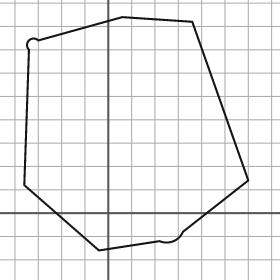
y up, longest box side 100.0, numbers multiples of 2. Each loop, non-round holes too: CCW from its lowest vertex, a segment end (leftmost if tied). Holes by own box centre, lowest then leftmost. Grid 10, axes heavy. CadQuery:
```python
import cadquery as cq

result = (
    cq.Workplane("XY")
    .moveTo(-4.0, -16.0)
    .lineTo(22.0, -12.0)
    .threePointArc((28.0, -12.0), (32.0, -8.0))
    .lineTo(60.0, 14.0)
    .lineTo(36.0, 82.0)
    .lineTo(6.0, 84.0)
    .lineTo(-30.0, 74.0)
    .threePointArc((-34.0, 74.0), (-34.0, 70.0))
    .lineTo(-36.0, 12.0)
    .close()
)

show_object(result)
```